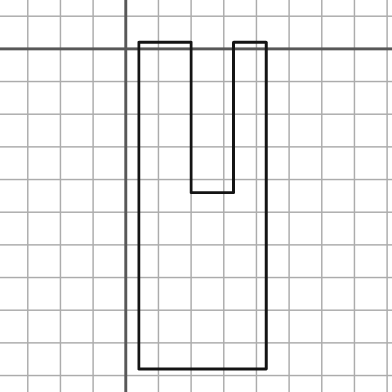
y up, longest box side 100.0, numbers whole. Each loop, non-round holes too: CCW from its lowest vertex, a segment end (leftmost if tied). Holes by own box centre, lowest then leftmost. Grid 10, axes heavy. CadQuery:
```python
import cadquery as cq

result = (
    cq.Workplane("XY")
    .moveTo(4.0, -98.0)
    .lineTo(43.0, -98.0)
    .lineTo(43.0, 2.0)
    .lineTo(33.0, 2.0)
    .lineTo(33.0, -44.0)
    .lineTo(20.0, -44.0)
    .lineTo(20.0, 2.0)
    .lineTo(4.0, 2.0)
    .close()
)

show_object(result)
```